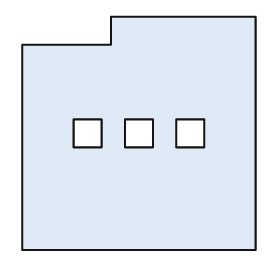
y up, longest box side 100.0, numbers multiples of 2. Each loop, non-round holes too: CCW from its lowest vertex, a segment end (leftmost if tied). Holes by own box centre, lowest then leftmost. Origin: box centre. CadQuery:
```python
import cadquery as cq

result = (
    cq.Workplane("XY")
    .moveTo(-50.0, -50.0)
    .lineTo(50.0, -50.0)
    .lineTo(50.0, 50.0)
    .lineTo(-12.0, 50.0)
    .lineTo(-12.0, 38.0)
    .lineTo(-50.0, 38.0)
    .close()
    .moveTo(-28.0, -6.0)
    .lineTo(-16.0, -6.0)
    .lineTo(-16.0, 6.0)
    .lineTo(-28.0, 6.0)
    .close()
    .moveTo(-6.0, -6.0)
    .lineTo(6.0, -6.0)
    .lineTo(6.0, 6.0)
    .lineTo(-6.0, 6.0)
    .close()
    .moveTo(16.0, -6.0)
    .lineTo(28.0, -6.0)
    .lineTo(28.0, 6.0)
    .lineTo(16.0, 6.0)
    .close()
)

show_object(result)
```